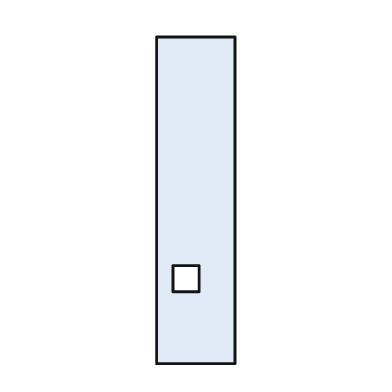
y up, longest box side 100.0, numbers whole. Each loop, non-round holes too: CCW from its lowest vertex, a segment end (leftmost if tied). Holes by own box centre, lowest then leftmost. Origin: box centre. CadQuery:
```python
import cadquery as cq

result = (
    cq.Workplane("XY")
    .moveTo(-12.0, -50.0)
    .lineTo(12.0, -50.0)
    .lineTo(12.0, 50.0)
    .lineTo(-12.0, 50.0)
    .close()
    .moveTo(-7.0, -28.0)
    .lineTo(1.0, -28.0)
    .lineTo(1.0, -20.0)
    .lineTo(-7.0, -20.0)
    .close()
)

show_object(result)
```